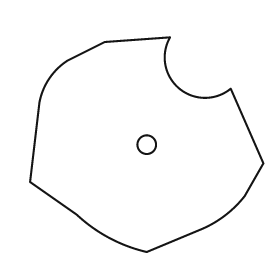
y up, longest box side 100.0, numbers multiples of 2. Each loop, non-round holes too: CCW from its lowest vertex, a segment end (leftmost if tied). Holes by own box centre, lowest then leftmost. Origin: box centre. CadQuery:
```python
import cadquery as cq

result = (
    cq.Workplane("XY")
    .moveTo(0.0, -46.0)
    .lineTo(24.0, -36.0)
    .threePointArc((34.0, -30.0), (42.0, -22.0))
    .lineTo(50.0, -8.0)
    .lineTo(36.0, 24.0)
    .threePointArc((14.0, 24.0), (10.0, 46.0))
    .lineTo(-18.0, 44.0)
    .lineTo(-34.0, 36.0)
    .threePointArc((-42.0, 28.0), (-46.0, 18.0))
    .lineTo(-50.0, -16.0)
    .lineTo(-30.0, -30.0)
    .threePointArc((-16.0, -40.0), (0.0, -46.0))
    .close()
    .moveTo(0.0, 0.0)
    .circle(4.0)
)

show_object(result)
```